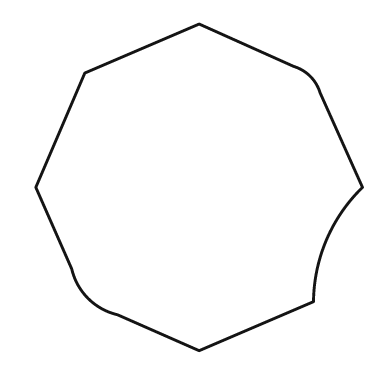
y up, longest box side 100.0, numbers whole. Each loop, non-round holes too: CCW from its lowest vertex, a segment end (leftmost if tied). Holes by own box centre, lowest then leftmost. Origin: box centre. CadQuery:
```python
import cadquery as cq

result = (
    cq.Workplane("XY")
    .moveTo(0.0, -50.0)
    .lineTo(35.0, -35.0)
    .threePointArc((39.0, -16.0), (50.0, 0.0))
    .lineTo(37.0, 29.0)
    .threePointArc((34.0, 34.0), (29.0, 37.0))
    .lineTo(0.0, 50.0)
    .lineTo(-35.0, 35.0)
    .lineTo(-50.0, 0.0)
    .lineTo(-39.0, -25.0)
    .threePointArc((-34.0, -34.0), (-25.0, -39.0))
    .close()
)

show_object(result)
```